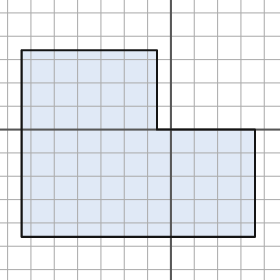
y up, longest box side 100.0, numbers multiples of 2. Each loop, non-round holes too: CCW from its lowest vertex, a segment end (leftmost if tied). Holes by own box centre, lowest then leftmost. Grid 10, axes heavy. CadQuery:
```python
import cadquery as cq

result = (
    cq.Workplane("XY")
    .moveTo(-64.0, -46.0)
    .lineTo(36.0, -46.0)
    .lineTo(36.0, 0.0)
    .lineTo(-6.0, 0.0)
    .lineTo(-6.0, 34.0)
    .lineTo(-64.0, 34.0)
    .close()
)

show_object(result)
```